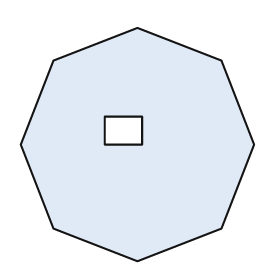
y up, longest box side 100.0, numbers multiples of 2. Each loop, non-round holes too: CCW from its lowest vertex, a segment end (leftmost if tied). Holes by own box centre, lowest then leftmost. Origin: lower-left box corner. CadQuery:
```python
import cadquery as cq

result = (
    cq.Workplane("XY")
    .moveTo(50.0, 0.0)
    .lineTo(86.0, 14.0)
    .lineTo(100.0, 50.0)
    .lineTo(86.0, 86.0)
    .lineTo(50.0, 100.0)
    .lineTo(14.0, 86.0)
    .lineTo(0.0, 50.0)
    .lineTo(14.0, 14.0)
    .close()
    .moveTo(36.0, 50.0)
    .lineTo(52.0, 50.0)
    .lineTo(52.0, 62.0)
    .lineTo(36.0, 62.0)
    .close()
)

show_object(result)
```